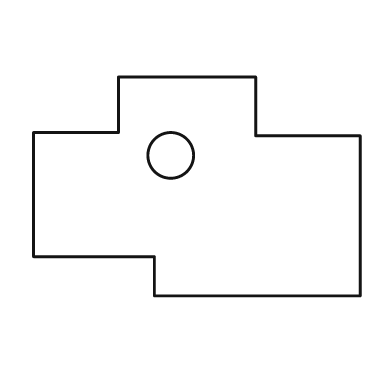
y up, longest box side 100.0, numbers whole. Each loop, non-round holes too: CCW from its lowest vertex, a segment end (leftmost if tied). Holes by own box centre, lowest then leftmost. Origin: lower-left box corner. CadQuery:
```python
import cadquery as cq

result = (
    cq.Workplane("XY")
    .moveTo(37.0, 0.0)
    .lineTo(100.0, 0.0)
    .lineTo(100.0, 49.0)
    .lineTo(68.0, 49.0)
    .lineTo(68.0, 67.0)
    .lineTo(26.0, 67.0)
    .lineTo(26.0, 50.0)
    .lineTo(0.0, 50.0)
    .lineTo(0.0, 12.0)
    .lineTo(37.0, 12.0)
    .close()
    .moveTo(42.0, 43.0)
    .circle(7.0)
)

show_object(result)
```